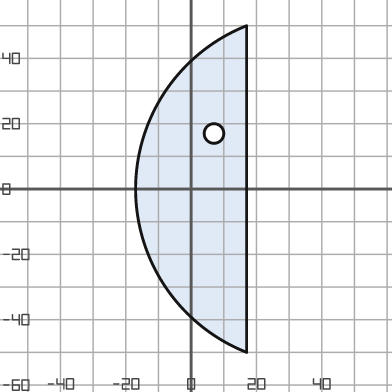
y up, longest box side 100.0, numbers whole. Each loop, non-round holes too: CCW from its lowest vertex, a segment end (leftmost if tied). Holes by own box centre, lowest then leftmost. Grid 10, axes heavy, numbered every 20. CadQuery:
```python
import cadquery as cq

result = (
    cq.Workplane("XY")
    .moveTo(17.0, -50.0)
    .lineTo(17.0, 50.0)
    .threePointArc((-17.0, 0.0), (17.0, -50.0))
    .close()
    .moveTo(7.0, 17.0)
    .circle(3.0)
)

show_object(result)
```